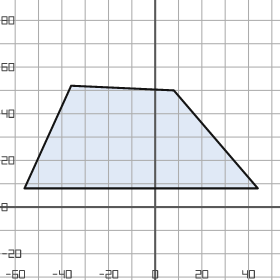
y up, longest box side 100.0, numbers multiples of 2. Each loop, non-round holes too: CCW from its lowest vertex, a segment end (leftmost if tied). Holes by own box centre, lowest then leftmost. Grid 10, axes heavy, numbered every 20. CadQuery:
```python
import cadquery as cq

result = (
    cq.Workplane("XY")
    .moveTo(-56.0, 8.0)
    .lineTo(44.0, 8.0)
    .lineTo(8.0, 50.0)
    .lineTo(-36.0, 52.0)
    .close()
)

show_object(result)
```